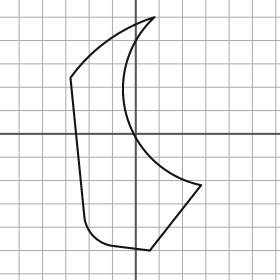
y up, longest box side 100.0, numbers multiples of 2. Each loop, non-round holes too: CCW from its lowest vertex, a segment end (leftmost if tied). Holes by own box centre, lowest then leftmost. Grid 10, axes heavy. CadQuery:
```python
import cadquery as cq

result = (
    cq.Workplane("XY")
    .moveTo(6.0, -50.0)
    .lineTo(28.0, -22.0)
    .threePointArc((-4.0, 8.0), (8.0, 50.0))
    .threePointArc((-12.0, 40.0), (-28.0, 24.0))
    .lineTo(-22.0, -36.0)
    .threePointArc((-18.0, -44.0), (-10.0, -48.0))
    .close()
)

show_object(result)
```